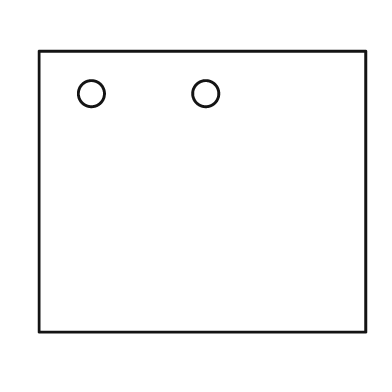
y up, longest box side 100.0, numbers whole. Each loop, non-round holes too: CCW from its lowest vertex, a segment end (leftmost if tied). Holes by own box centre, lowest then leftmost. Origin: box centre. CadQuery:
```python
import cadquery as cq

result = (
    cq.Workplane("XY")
    .moveTo(-50.0, -43.0)
    .lineTo(50.0, -43.0)
    .lineTo(50.0, 43.0)
    .lineTo(-50.0, 43.0)
    .close()
    .moveTo(-34.0, 30.0)
    .circle(4.0)
    .moveTo(1.0, 30.0)
    .circle(4.0)
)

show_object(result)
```